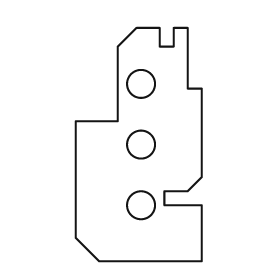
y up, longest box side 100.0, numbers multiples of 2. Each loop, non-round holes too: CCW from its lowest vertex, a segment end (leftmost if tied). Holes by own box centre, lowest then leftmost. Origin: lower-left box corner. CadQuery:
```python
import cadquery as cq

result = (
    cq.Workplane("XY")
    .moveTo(10.0, 0.0)
    .lineTo(54.0, 0.0)
    .lineTo(54.0, 24.0)
    .lineTo(38.0, 24.0)
    .lineTo(38.0, 30.0)
    .lineTo(48.0, 30.0)
    .lineTo(54.0, 36.0)
    .lineTo(54.0, 74.0)
    .lineTo(48.0, 74.0)
    .lineTo(48.0, 100.0)
    .lineTo(42.0, 100.0)
    .lineTo(42.0, 92.0)
    .lineTo(36.0, 92.0)
    .lineTo(36.0, 100.0)
    .lineTo(26.0, 100.0)
    .lineTo(18.0, 92.0)
    .lineTo(18.0, 60.0)
    .lineTo(0.0, 60.0)
    .lineTo(0.0, 10.0)
    .close()
    .moveTo(28.0, 24.0)
    .circle(6.0)
    .moveTo(28.0, 50.0)
    .circle(6.0)
    .moveTo(28.0, 76.0)
    .circle(6.0)
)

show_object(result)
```